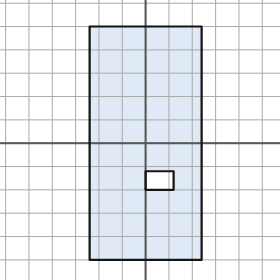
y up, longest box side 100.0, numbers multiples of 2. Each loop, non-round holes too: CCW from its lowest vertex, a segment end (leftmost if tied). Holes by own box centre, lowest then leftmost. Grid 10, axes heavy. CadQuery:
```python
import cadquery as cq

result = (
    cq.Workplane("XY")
    .moveTo(-24.0, -50.0)
    .lineTo(24.0, -50.0)
    .lineTo(24.0, 50.0)
    .lineTo(-24.0, 50.0)
    .close()
    .moveTo(0.0, -20.0)
    .lineTo(12.0, -20.0)
    .lineTo(12.0, -12.0)
    .lineTo(0.0, -12.0)
    .close()
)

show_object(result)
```